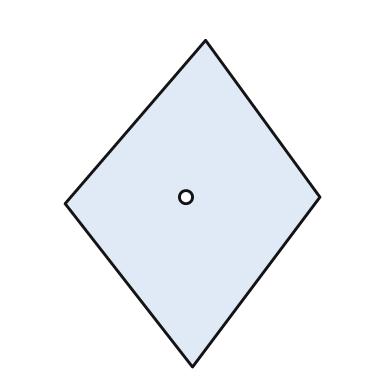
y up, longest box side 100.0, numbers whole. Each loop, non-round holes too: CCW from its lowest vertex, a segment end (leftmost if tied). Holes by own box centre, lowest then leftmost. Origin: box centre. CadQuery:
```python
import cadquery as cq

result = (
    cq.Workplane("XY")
    .moveTo(0.0, -50.0)
    .lineTo(39.0, 2.0)
    .lineTo(4.0, 50.0)
    .lineTo(-39.0, 0.0)
    .close()
    .moveTo(-2.0, 2.0)
    .circle(2.0)
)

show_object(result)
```